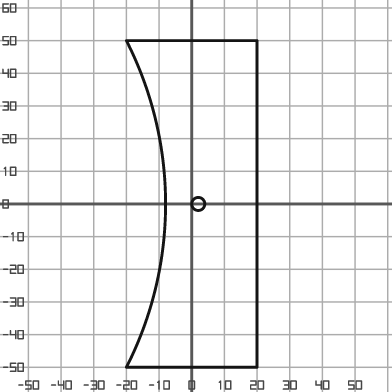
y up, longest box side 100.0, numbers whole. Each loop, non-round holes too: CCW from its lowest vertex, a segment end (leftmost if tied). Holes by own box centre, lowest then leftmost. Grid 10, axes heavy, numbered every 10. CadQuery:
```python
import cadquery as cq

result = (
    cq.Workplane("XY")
    .moveTo(-20.0, -50.0)
    .lineTo(20.0, -50.0)
    .lineTo(20.0, 50.0)
    .lineTo(-20.0, 50.0)
    .threePointArc((-8.0, 0.0), (-20.0, -50.0))
    .close()
    .moveTo(2.0, 0.0)
    .circle(2.0)
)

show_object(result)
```